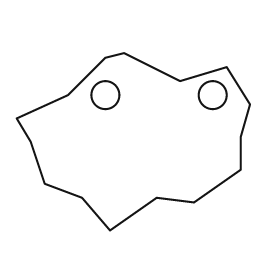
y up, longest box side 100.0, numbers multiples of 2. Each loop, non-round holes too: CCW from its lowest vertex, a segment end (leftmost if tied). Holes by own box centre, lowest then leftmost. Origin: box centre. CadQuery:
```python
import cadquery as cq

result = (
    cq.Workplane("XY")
    .moveTo(-10.0, -38.0)
    .lineTo(10.0, -24.0)
    .lineTo(26.0, -26.0)
    .lineTo(46.0, -12.0)
    .lineTo(46.0, 2.0)
    .lineTo(50.0, 16.0)
    .lineTo(40.0, 32.0)
    .lineTo(20.0, 26.0)
    .lineTo(-4.0, 38.0)
    .lineTo(-12.0, 36.0)
    .lineTo(-28.0, 20.0)
    .lineTo(-50.0, 10.0)
    .lineTo(-44.0, 0.0)
    .lineTo(-38.0, -18.0)
    .lineTo(-22.0, -24.0)
    .close()
    .moveTo(-12.0, 20.0)
    .circle(6.0)
    .moveTo(34.0, 20.0)
    .circle(6.0)
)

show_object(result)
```